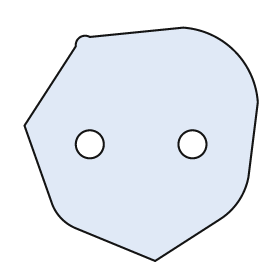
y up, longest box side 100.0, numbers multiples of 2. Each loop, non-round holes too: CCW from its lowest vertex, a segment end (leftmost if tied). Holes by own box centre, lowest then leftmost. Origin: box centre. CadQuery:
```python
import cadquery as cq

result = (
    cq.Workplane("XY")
    .moveTo(6.0, -50.0)
    .lineTo(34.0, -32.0)
    .threePointArc((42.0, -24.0), (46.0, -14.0))
    .lineTo(50.0, 18.0)
    .threePointArc((40.0, 40.0), (18.0, 50.0))
    .lineTo(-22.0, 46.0)
    .threePointArc((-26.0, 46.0), (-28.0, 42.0))
    .lineTo(-50.0, 8.0)
    .lineTo(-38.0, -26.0)
    .threePointArc((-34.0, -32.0), (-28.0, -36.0))
    .close()
    .moveTo(-22.0, 0.0)
    .circle(6.0)
    .moveTo(22.0, 0.0)
    .circle(6.0)
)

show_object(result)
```